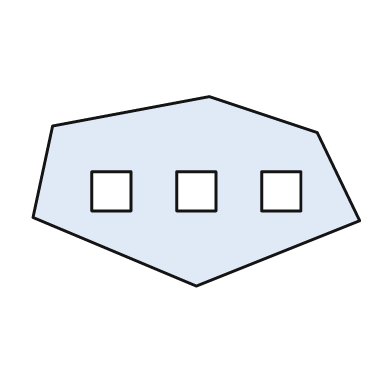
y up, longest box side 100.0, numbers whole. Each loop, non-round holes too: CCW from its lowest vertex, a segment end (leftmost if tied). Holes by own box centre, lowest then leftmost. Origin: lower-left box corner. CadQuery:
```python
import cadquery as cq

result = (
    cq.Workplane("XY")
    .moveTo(50.0, 0.0)
    .lineTo(100.0, 20.0)
    .lineTo(87.0, 47.0)
    .lineTo(54.0, 58.0)
    .lineTo(6.0, 49.0)
    .lineTo(0.0, 21.0)
    .close()
    .moveTo(18.0, 23.0)
    .lineTo(30.0, 23.0)
    .lineTo(30.0, 35.0)
    .lineTo(18.0, 35.0)
    .close()
    .moveTo(44.0, 23.0)
    .lineTo(56.0, 23.0)
    .lineTo(56.0, 35.0)
    .lineTo(44.0, 35.0)
    .close()
    .moveTo(70.0, 23.0)
    .lineTo(82.0, 23.0)
    .lineTo(82.0, 35.0)
    .lineTo(70.0, 35.0)
    .close()
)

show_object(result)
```